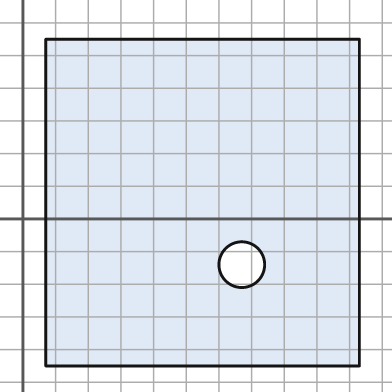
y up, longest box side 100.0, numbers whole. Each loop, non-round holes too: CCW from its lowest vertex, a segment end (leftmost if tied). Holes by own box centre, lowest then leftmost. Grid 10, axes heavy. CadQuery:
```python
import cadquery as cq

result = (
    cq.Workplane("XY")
    .moveTo(7.0, -45.0)
    .lineTo(103.0, -45.0)
    .lineTo(103.0, 55.0)
    .lineTo(7.0, 55.0)
    .close()
    .moveTo(67.0, -14.0)
    .circle(7.0)
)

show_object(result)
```